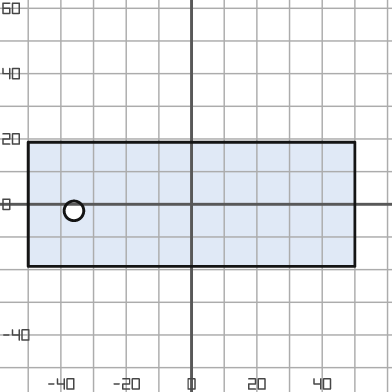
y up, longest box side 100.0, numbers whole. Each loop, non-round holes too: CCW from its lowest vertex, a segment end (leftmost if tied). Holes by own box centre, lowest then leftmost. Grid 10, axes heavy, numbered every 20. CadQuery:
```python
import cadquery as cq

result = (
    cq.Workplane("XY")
    .moveTo(-50.0, -19.0)
    .lineTo(50.0, -19.0)
    .lineTo(50.0, 19.0)
    .lineTo(-50.0, 19.0)
    .close()
    .moveTo(-36.0, -2.0)
    .circle(3.0)
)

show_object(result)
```